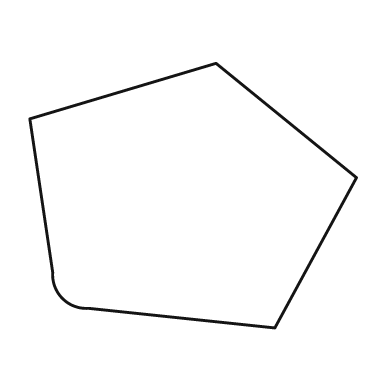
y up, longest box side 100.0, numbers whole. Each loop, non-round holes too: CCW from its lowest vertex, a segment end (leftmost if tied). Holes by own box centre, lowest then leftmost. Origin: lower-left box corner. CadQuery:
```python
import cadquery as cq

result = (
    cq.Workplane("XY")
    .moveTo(75.0, 0.0)
    .lineTo(100.0, 46.0)
    .lineTo(57.0, 81.0)
    .lineTo(0.0, 64.0)
    .lineTo(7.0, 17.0)
    .threePointArc((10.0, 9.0), (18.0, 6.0))
    .close()
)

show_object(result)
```